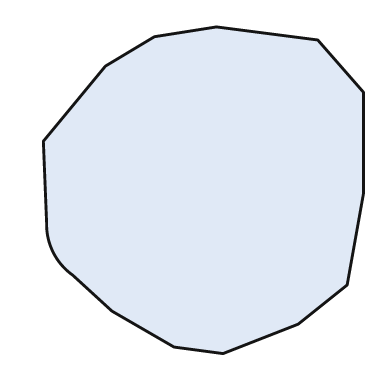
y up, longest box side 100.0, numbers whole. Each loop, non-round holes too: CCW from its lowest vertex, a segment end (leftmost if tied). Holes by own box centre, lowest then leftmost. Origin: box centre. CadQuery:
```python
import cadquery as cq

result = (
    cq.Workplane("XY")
    .moveTo(6.0, -50.0)
    .lineTo(29.0, -41.0)
    .lineTo(44.0, -29.0)
    .lineTo(49.0, -1.0)
    .lineTo(49.0, 30.0)
    .lineTo(35.0, 46.0)
    .lineTo(4.0, 50.0)
    .lineTo(-15.0, 47.0)
    .lineTo(-30.0, 38.0)
    .lineTo(-49.0, 15.0)
    .lineTo(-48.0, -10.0)
    .threePointArc((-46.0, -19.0), (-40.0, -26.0))
    .lineTo(-28.0, -37.0)
    .lineTo(-9.0, -48.0)
    .close()
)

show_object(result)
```